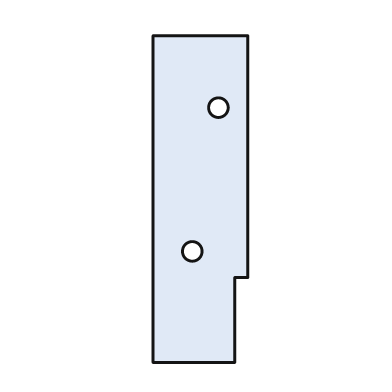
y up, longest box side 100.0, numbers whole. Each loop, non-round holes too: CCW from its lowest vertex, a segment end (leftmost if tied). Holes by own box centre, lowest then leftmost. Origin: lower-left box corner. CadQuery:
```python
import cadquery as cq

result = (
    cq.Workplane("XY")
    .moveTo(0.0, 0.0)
    .lineTo(25.0, 0.0)
    .lineTo(25.0, 26.0)
    .lineTo(29.0, 26.0)
    .lineTo(29.0, 100.0)
    .lineTo(0.0, 100.0)
    .close()
    .moveTo(12.0, 34.0)
    .circle(3.0)
    .moveTo(20.0, 78.0)
    .circle(3.0)
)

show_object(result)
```